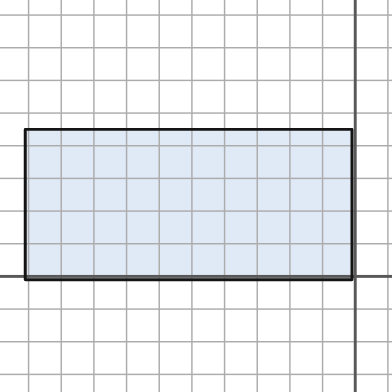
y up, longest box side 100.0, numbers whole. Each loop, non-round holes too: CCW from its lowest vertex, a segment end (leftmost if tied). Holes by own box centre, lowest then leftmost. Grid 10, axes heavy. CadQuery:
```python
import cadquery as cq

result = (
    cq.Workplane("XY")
    .moveTo(-101.0, -1.0)
    .lineTo(-1.0, -1.0)
    .lineTo(-1.0, 45.0)
    .lineTo(-101.0, 45.0)
    .close()
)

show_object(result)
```